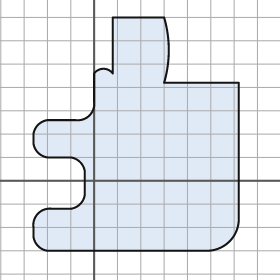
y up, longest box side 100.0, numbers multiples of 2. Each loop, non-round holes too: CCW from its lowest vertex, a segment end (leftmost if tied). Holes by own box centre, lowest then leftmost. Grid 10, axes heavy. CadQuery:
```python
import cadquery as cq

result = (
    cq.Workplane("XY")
    .moveTo(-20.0, -30.0)
    .lineTo(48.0, -30.0)
    .threePointArc((58.0, -26.0), (62.0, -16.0))
    .lineTo(62.0, 42.0)
    .lineTo(30.0, 42.0)
    .threePointArc((32.0, 56.0), (30.0, 70.0))
    .lineTo(8.0, 70.0)
    .lineTo(8.0, 46.0)
    .threePointArc((4.0, 48.0), (0.0, 46.0))
    .lineTo(0.0, 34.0)
    .threePointArc((-2.0, 28.0), (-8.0, 26.0))
    .lineTo(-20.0, 26.0)
    .threePointArc((-24.0, 24.0), (-26.0, 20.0))
    .lineTo(-26.0, 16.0)
    .threePointArc((-24.0, 12.0), (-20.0, 10.0))
    .lineTo(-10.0, 10.0)
    .threePointArc((-6.0, 8.0), (-4.0, 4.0))
    .lineTo(-4.0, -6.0)
    .threePointArc((-6.0, -10.0), (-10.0, -12.0))
    .lineTo(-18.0, -12.0)
    .threePointArc((-24.0, -14.0), (-26.0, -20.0))
    .lineTo(-26.0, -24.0)
    .threePointArc((-24.0, -28.0), (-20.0, -30.0))
    .close()
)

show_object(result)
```